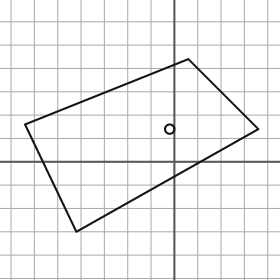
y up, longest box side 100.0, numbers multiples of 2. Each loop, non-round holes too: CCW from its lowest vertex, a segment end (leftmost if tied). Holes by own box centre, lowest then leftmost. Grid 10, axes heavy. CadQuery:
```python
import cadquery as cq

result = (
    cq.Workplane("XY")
    .moveTo(-42.0, -30.0)
    .lineTo(36.0, 14.0)
    .lineTo(6.0, 44.0)
    .lineTo(-64.0, 16.0)
    .close()
    .moveTo(-2.0, 14.0)
    .circle(2.0)
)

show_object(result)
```